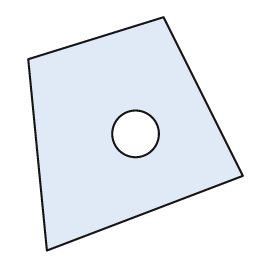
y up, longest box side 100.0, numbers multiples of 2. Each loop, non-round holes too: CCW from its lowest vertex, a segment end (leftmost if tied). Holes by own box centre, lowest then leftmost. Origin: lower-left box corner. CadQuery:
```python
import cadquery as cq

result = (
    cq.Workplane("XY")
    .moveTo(8.0, 0.0)
    .lineTo(92.0, 32.0)
    .lineTo(58.0, 100.0)
    .lineTo(0.0, 82.0)
    .close()
    .moveTo(46.0, 50.0)
    .circle(10.0)
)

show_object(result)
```